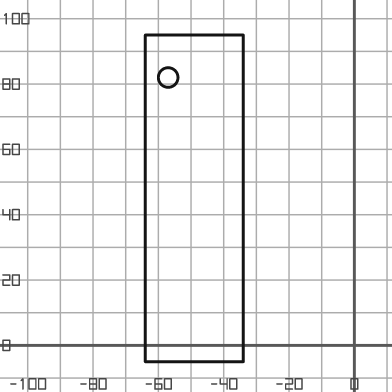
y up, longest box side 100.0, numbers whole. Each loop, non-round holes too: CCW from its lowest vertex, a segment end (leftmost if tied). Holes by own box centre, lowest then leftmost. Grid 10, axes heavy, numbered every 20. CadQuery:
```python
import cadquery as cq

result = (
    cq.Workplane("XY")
    .moveTo(-64.0, -5.0)
    .lineTo(-34.0, -5.0)
    .lineTo(-34.0, 95.0)
    .lineTo(-64.0, 95.0)
    .close()
    .moveTo(-57.0, 82.0)
    .circle(3.0)
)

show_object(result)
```